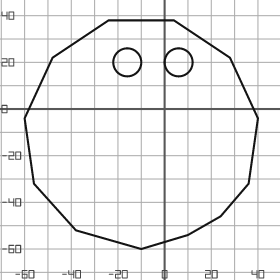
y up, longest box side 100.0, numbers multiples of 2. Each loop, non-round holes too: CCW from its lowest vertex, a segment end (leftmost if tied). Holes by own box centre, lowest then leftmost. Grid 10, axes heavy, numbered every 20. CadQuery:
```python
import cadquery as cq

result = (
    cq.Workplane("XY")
    .moveTo(-10.0, -60.0)
    .lineTo(10.0, -54.0)
    .lineTo(24.0, -46.0)
    .lineTo(36.0, -32.0)
    .lineTo(40.0, -4.0)
    .lineTo(28.0, 22.0)
    .lineTo(4.0, 38.0)
    .lineTo(-24.0, 38.0)
    .lineTo(-48.0, 22.0)
    .lineTo(-60.0, -4.0)
    .lineTo(-56.0, -32.0)
    .lineTo(-38.0, -52.0)
    .close()
    .moveTo(-16.0, 20.0)
    .circle(6.0)
    .moveTo(6.0, 20.0)
    .circle(6.0)
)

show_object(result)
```